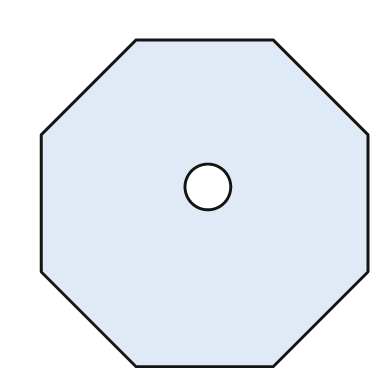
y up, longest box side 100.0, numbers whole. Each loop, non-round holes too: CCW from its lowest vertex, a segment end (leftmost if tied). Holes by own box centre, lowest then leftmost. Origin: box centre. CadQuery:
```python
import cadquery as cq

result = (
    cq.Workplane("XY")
    .moveTo(-21.0, -50.0)
    .lineTo(21.0, -50.0)
    .lineTo(50.0, -21.0)
    .lineTo(50.0, 21.0)
    .lineTo(21.0, 50.0)
    .lineTo(-21.0, 50.0)
    .lineTo(-50.0, 21.0)
    .lineTo(-50.0, -21.0)
    .close()
    .moveTo(1.0, 5.0)
    .circle(7.0)
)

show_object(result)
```